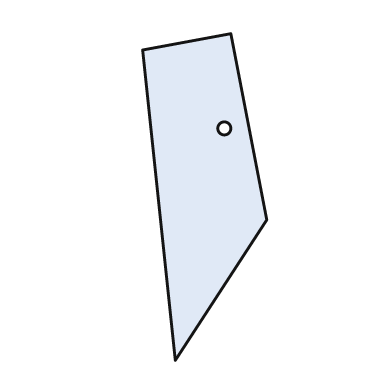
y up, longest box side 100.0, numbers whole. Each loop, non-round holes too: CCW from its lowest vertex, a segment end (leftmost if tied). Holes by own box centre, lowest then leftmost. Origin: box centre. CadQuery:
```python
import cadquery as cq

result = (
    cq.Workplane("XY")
    .moveTo(-9.0, -50.0)
    .lineTo(19.0, -7.0)
    .lineTo(8.0, 50.0)
    .lineTo(-19.0, 45.0)
    .close()
    .moveTo(6.0, 21.0)
    .circle(2.0)
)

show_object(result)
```